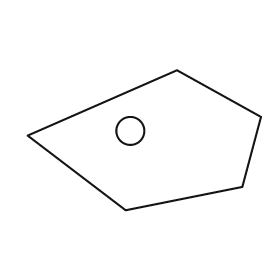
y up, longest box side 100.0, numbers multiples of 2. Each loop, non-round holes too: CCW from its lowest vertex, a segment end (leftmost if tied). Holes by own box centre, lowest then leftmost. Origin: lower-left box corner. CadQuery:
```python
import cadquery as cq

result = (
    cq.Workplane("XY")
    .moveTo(42.0, 0.0)
    .lineTo(92.0, 10.0)
    .lineTo(100.0, 40.0)
    .lineTo(64.0, 60.0)
    .lineTo(0.0, 32.0)
    .close()
    .moveTo(44.0, 34.0)
    .circle(6.0)
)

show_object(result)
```